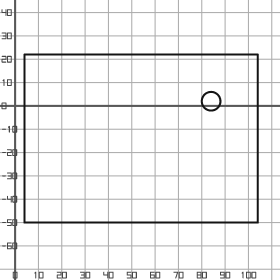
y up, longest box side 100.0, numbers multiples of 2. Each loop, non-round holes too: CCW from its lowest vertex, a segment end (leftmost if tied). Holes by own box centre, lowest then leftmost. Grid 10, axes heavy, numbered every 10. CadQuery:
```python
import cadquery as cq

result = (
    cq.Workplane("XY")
    .moveTo(4.0, -50.0)
    .lineTo(104.0, -50.0)
    .lineTo(104.0, 22.0)
    .lineTo(4.0, 22.0)
    .close()
    .moveTo(84.0, 2.0)
    .circle(4.0)
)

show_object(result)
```